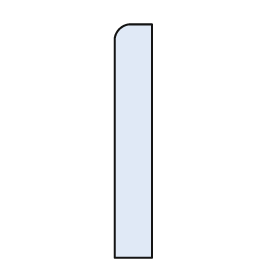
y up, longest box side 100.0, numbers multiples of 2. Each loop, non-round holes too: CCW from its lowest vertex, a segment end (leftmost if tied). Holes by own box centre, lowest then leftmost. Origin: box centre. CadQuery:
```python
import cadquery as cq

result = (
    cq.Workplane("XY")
    .moveTo(-8.0, -50.0)
    .lineTo(8.0, -50.0)
    .lineTo(8.0, 50.0)
    .lineTo(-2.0, 50.0)
    .threePointArc((-6.0, 48.0), (-8.0, 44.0))
    .close()
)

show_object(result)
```